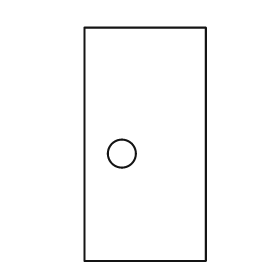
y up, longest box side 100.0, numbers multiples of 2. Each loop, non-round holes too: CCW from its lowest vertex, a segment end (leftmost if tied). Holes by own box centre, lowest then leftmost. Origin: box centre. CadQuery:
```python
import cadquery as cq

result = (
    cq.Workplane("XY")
    .moveTo(-26.0, -50.0)
    .lineTo(26.0, -50.0)
    .lineTo(26.0, 50.0)
    .lineTo(-26.0, 50.0)
    .close()
    .moveTo(-10.0, -4.0)
    .circle(6.0)
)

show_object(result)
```